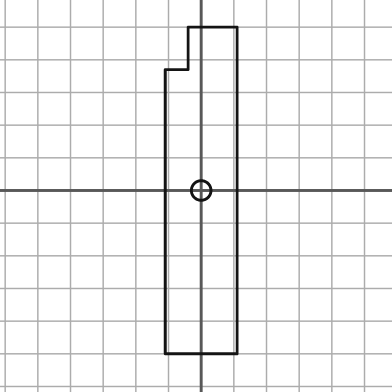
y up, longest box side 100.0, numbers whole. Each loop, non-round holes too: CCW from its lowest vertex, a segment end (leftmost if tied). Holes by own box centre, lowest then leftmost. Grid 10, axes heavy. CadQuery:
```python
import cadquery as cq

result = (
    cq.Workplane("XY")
    .moveTo(-11.0, -50.0)
    .lineTo(11.0, -50.0)
    .lineTo(11.0, 50.0)
    .lineTo(-4.0, 50.0)
    .lineTo(-4.0, 37.0)
    .lineTo(-11.0, 37.0)
    .close()
    .moveTo(0.0, 0.0)
    .circle(3.0)
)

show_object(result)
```